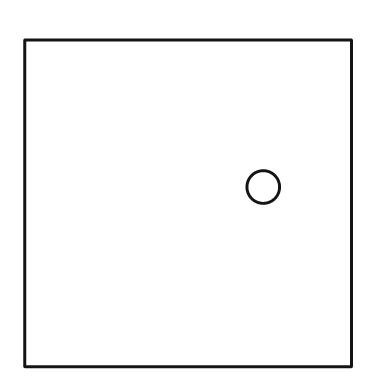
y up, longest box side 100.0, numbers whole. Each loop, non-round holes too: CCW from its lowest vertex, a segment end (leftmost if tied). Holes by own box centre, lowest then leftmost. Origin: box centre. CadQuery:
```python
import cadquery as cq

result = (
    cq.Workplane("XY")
    .moveTo(-50.0, -50.0)
    .lineTo(50.0, -50.0)
    .lineTo(50.0, 50.0)
    .lineTo(-50.0, 50.0)
    .close()
    .moveTo(23.0, 5.0)
    .circle(5.0)
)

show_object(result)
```